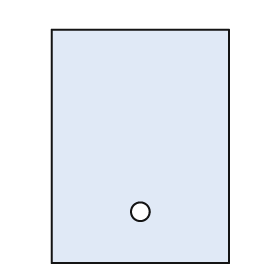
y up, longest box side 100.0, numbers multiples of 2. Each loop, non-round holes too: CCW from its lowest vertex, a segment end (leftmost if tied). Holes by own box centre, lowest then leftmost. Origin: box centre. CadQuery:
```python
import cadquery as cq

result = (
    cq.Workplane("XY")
    .moveTo(-38.0, -50.0)
    .lineTo(38.0, -50.0)
    .lineTo(38.0, 50.0)
    .lineTo(-38.0, 50.0)
    .close()
    .moveTo(0.0, -28.0)
    .circle(4.0)
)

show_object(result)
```